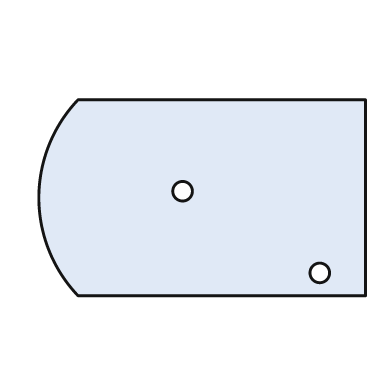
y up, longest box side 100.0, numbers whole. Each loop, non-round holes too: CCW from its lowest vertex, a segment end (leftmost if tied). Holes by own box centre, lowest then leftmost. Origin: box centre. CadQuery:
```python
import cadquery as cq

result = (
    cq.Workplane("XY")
    .moveTo(-38.0, -30.0)
    .lineTo(50.0, -30.0)
    .lineTo(50.0, 30.0)
    .lineTo(-38.0, 30.0)
    .threePointArc((-50.0, 0.0), (-38.0, -30.0))
    .close()
    .moveTo(36.0, -23.0)
    .circle(3.0)
    .moveTo(-6.0, 2.0)
    .circle(3.0)
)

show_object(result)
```